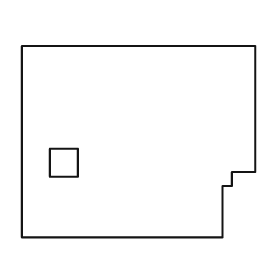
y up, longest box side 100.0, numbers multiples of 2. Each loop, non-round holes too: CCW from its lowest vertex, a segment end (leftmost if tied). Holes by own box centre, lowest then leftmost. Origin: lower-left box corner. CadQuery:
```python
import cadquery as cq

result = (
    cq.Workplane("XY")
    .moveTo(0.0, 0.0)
    .lineTo(86.0, 0.0)
    .lineTo(86.0, 22.0)
    .lineTo(90.0, 22.0)
    .lineTo(90.0, 28.0)
    .lineTo(100.0, 28.0)
    .lineTo(100.0, 82.0)
    .lineTo(0.0, 82.0)
    .close()
    .moveTo(12.0, 26.0)
    .lineTo(24.0, 26.0)
    .lineTo(24.0, 38.0)
    .lineTo(12.0, 38.0)
    .close()
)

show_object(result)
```